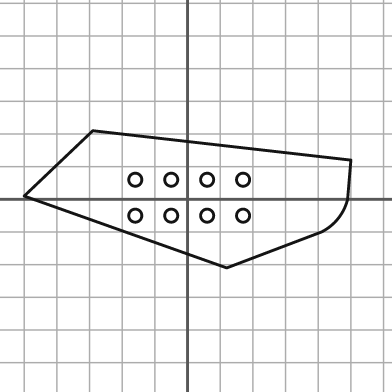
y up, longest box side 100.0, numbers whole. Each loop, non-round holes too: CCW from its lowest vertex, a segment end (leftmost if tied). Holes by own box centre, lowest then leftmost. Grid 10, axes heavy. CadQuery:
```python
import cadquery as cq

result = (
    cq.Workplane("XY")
    .moveTo(12.0, -21.0)
    .lineTo(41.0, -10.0)
    .threePointArc((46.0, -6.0), (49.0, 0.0))
    .lineTo(50.0, 12.0)
    .lineTo(-29.0, 21.0)
    .lineTo(-50.0, 1.0)
    .close()
    .moveTo(-16.0, -5.0)
    .circle(2.0)
    .moveTo(-5.0, -5.0)
    .circle(2.0)
    .moveTo(6.0, -5.0)
    .circle(2.0)
    .moveTo(17.0, -5.0)
    .circle(2.0)
    .moveTo(-16.0, 6.0)
    .circle(2.0)
    .moveTo(-5.0, 6.0)
    .circle(2.0)
    .moveTo(6.0, 6.0)
    .circle(2.0)
    .moveTo(17.0, 6.0)
    .circle(2.0)
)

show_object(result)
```